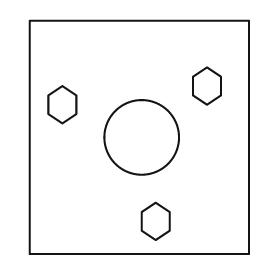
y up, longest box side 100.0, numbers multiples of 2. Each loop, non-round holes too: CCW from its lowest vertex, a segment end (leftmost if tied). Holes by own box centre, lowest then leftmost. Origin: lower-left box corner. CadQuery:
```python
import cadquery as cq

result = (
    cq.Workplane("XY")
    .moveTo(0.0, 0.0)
    .lineTo(94.0, 0.0)
    .lineTo(94.0, 100.0)
    .lineTo(0.0, 100.0)
    .close()
    .moveTo(54.0, 6.0)
    .lineTo(60.0, 10.0)
    .lineTo(60.0, 18.0)
    .lineTo(54.0, 22.0)
    .lineTo(48.0, 18.0)
    .lineTo(48.0, 10.0)
    .close()
    .moveTo(48.0, 50.0)
    .circle(16.0)
    .moveTo(14.0, 56.0)
    .lineTo(20.0, 60.0)
    .lineTo(20.0, 68.0)
    .lineTo(14.0, 72.0)
    .lineTo(8.0, 68.0)
    .lineTo(8.0, 60.0)
    .close()
    .moveTo(76.0, 64.0)
    .lineTo(82.0, 68.0)
    .lineTo(82.0, 76.0)
    .lineTo(76.0, 80.0)
    .lineTo(70.0, 76.0)
    .lineTo(70.0, 68.0)
    .close()
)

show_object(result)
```